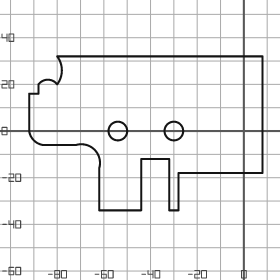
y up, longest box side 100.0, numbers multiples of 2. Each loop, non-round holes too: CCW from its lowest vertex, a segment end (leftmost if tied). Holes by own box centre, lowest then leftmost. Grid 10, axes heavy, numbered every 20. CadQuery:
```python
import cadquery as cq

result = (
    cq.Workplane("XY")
    .moveTo(-62.0, -34.0)
    .lineTo(-44.0, -34.0)
    .lineTo(-44.0, -12.0)
    .lineTo(-32.0, -12.0)
    .lineTo(-32.0, -34.0)
    .lineTo(-28.0, -34.0)
    .lineTo(-28.0, -18.0)
    .lineTo(8.0, -18.0)
    .lineTo(8.0, 32.0)
    .lineTo(-80.0, 32.0)
    .threePointArc((-78.0, 26.0), (-80.0, 20.0))
    .threePointArc((-84.0, 22.0), (-88.0, 20.0))
    .lineTo(-88.0, 16.0)
    .lineTo(-92.0, 16.0)
    .lineTo(-92.0, 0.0)
    .threePointArc((-90.0, -4.0), (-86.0, -6.0))
    .lineTo(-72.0, -6.0)
    .threePointArc((-64.0, -8.0), (-62.0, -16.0))
    .close()
    .moveTo(-54.0, 0.0)
    .circle(4.0)
    .moveTo(-30.0, 0.0)
    .circle(4.0)
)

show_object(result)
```